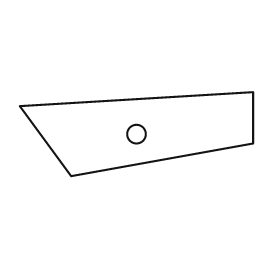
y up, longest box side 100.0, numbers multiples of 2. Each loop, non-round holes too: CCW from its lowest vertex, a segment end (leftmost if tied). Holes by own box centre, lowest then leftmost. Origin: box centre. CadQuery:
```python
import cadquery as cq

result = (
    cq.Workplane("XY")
    .moveTo(-28.0, -18.0)
    .lineTo(50.0, -4.0)
    .lineTo(50.0, 18.0)
    .lineTo(-50.0, 12.0)
    .close()
    .moveTo(0.0, 0.0)
    .circle(4.0)
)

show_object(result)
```